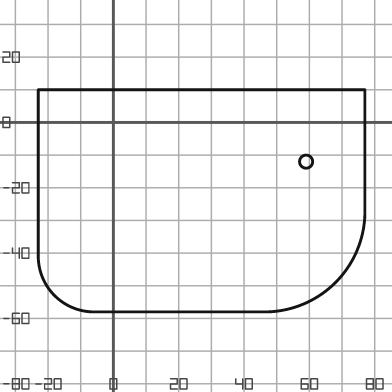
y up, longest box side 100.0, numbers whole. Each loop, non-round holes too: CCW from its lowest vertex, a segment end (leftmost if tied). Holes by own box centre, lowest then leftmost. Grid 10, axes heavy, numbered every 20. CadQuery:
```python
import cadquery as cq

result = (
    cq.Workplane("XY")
    .moveTo(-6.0, -58.0)
    .lineTo(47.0, -58.0)
    .threePointArc((68.0, -49.0), (77.0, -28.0))
    .lineTo(77.0, 10.0)
    .lineTo(-23.0, 10.0)
    .lineTo(-23.0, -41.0)
    .threePointArc((-18.0, -53.0), (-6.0, -58.0))
    .close()
    .moveTo(59.0, -12.0)
    .circle(2.0)
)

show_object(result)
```